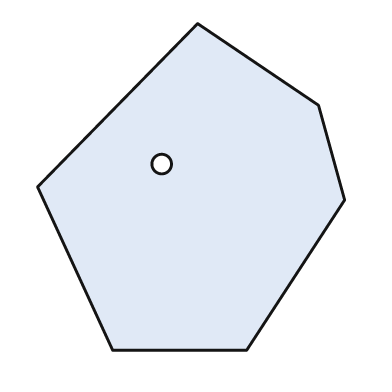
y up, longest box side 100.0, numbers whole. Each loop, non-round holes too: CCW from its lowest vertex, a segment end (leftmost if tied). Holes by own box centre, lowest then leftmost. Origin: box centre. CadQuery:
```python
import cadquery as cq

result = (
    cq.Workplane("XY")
    .moveTo(-24.0, -50.0)
    .lineTo(17.0, -50.0)
    .lineTo(47.0, -4.0)
    .lineTo(39.0, 25.0)
    .lineTo(2.0, 50.0)
    .lineTo(-47.0, 0.0)
    .close()
    .moveTo(-9.0, 7.0)
    .circle(3.0)
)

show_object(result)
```